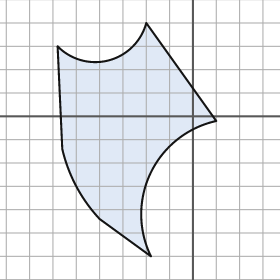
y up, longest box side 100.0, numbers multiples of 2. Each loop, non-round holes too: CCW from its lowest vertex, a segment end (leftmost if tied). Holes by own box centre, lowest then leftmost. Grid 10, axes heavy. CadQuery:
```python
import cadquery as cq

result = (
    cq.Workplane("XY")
    .moveTo(-18.0, -60.0)
    .threePointArc((-18.0, -24.0), (10.0, -2.0))
    .lineTo(-20.0, 40.0)
    .threePointArc((-36.0, 24.0), (-58.0, 30.0))
    .lineTo(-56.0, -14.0)
    .threePointArc((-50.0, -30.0), (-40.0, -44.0))
    .close()
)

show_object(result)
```